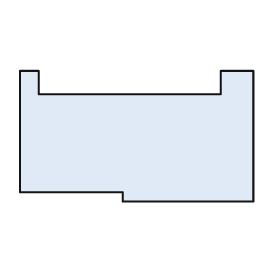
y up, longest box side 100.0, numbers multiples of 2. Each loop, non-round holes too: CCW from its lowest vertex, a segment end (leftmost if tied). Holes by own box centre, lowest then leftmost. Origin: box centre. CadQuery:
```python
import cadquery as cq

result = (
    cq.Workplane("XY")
    .moveTo(-6.0, -28.0)
    .lineTo(50.0, -28.0)
    .lineTo(50.0, 28.0)
    .lineTo(36.0, 28.0)
    .lineTo(36.0, 18.0)
    .lineTo(-42.0, 18.0)
    .lineTo(-42.0, 28.0)
    .lineTo(-50.0, 28.0)
    .lineTo(-50.0, -24.0)
    .lineTo(-6.0, -24.0)
    .close()
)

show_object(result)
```